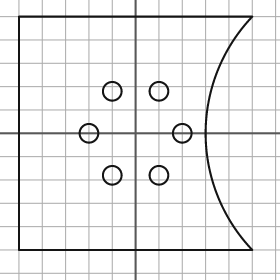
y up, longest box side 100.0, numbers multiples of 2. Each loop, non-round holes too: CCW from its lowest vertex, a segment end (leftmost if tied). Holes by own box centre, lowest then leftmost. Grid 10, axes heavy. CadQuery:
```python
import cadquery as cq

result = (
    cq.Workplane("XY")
    .moveTo(-50.0, -50.0)
    .lineTo(50.0, -50.0)
    .threePointArc((30.0, 0.0), (50.0, 50.0))
    .lineTo(-50.0, 50.0)
    .close()
    .moveTo(-10.0, -18.0)
    .circle(4.0)
    .moveTo(10.0, -18.0)
    .circle(4.0)
    .moveTo(-20.0, 0.0)
    .circle(4.0)
    .moveTo(20.0, 0.0)
    .circle(4.0)
    .moveTo(-10.0, 18.0)
    .circle(4.0)
    .moveTo(10.0, 18.0)
    .circle(4.0)
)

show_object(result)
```